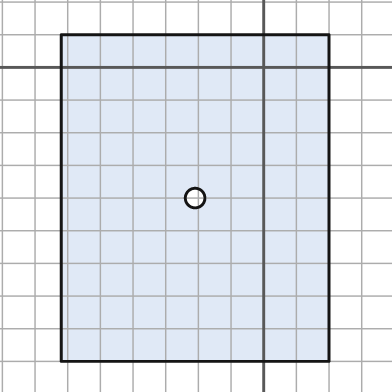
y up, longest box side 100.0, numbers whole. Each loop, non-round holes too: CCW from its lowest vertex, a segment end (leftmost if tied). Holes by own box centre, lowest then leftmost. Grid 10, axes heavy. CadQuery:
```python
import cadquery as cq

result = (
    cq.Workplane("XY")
    .moveTo(-62.0, -90.0)
    .lineTo(20.0, -90.0)
    .lineTo(20.0, 10.0)
    .lineTo(-62.0, 10.0)
    .close()
    .moveTo(-21.0, -40.0)
    .circle(3.0)
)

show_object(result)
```